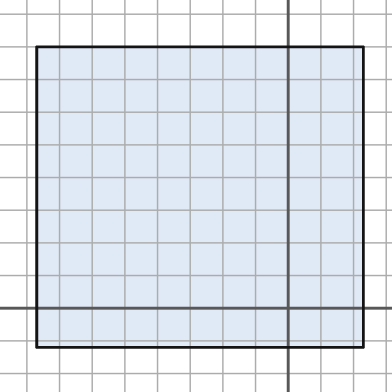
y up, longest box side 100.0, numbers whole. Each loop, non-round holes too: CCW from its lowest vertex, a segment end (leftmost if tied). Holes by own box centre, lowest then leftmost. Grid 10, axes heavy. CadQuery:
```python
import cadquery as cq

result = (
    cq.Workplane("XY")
    .moveTo(-77.0, -12.0)
    .lineTo(23.0, -12.0)
    .lineTo(23.0, 80.0)
    .lineTo(-77.0, 80.0)
    .close()
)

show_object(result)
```